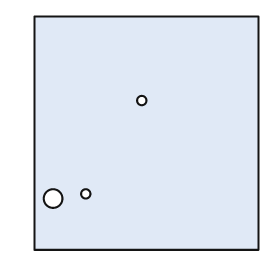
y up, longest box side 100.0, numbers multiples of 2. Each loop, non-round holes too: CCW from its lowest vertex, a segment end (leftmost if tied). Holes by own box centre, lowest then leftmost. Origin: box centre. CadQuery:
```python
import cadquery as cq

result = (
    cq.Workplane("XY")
    .moveTo(-48.0, -50.0)
    .lineTo(48.0, -50.0)
    .lineTo(48.0, 50.0)
    .lineTo(-48.0, 50.0)
    .close()
    .moveTo(-40.0, -28.0)
    .circle(4.0)
    .moveTo(-26.0, -26.0)
    .circle(2.0)
    .moveTo(-2.0, 14.0)
    .circle(2.0)
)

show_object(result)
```